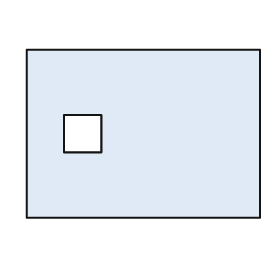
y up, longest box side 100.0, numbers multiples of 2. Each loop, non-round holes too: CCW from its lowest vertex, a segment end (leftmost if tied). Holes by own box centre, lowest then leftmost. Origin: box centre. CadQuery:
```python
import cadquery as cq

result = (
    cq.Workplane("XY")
    .moveTo(-50.0, -36.0)
    .lineTo(50.0, -36.0)
    .lineTo(50.0, 36.0)
    .lineTo(-50.0, 36.0)
    .close()
    .moveTo(-34.0, -8.0)
    .lineTo(-18.0, -8.0)
    .lineTo(-18.0, 8.0)
    .lineTo(-34.0, 8.0)
    .close()
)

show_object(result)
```